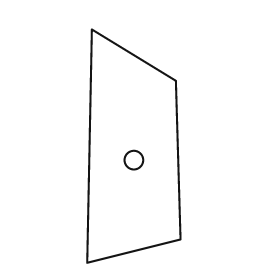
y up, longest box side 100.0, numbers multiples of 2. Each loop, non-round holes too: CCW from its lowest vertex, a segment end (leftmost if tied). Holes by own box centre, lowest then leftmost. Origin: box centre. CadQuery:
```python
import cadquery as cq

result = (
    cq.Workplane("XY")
    .moveTo(-20.0, -50.0)
    .lineTo(20.0, -40.0)
    .lineTo(18.0, 28.0)
    .lineTo(-18.0, 50.0)
    .close()
    .moveTo(0.0, -6.0)
    .circle(4.0)
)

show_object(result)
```